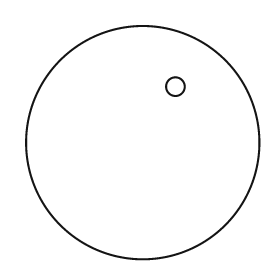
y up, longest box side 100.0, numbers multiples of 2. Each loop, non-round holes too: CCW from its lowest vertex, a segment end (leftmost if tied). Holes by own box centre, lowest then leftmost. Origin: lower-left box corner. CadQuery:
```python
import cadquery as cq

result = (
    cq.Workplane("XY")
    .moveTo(50.0, 50.0)
    .circle(50.0)
    .moveTo(64.0, 74.0)
    .circle(4.0)
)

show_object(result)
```